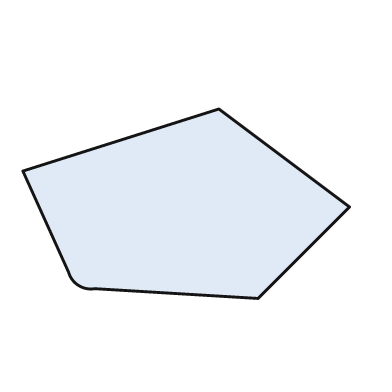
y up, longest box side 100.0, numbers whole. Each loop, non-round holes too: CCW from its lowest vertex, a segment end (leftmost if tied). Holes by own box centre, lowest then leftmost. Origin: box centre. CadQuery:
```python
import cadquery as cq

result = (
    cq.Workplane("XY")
    .moveTo(22.0, -29.0)
    .lineTo(50.0, -1.0)
    .lineTo(10.0, 29.0)
    .lineTo(-50.0, 10.0)
    .lineTo(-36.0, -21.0)
    .threePointArc((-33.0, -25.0), (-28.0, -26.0))
    .close()
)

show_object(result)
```